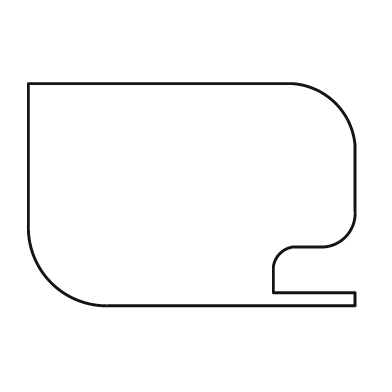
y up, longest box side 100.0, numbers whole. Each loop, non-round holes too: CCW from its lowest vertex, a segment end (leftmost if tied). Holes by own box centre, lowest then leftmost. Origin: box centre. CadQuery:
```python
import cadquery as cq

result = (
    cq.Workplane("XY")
    .moveTo(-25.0, -34.0)
    .lineTo(50.0, -34.0)
    .lineTo(50.0, -30.0)
    .lineTo(25.0, -30.0)
    .lineTo(25.0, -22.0)
    .threePointArc((27.0, -18.0), (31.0, -16.0))
    .lineTo(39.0, -16.0)
    .threePointArc((47.0, -13.0), (50.0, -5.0))
    .lineTo(50.0, 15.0)
    .threePointArc((44.0, 28.0), (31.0, 34.0))
    .lineTo(-50.0, 34.0)
    .lineTo(-50.0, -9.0)
    .threePointArc((-43.0, -27.0), (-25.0, -34.0))
    .close()
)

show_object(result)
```